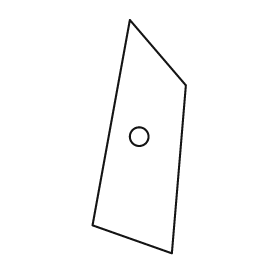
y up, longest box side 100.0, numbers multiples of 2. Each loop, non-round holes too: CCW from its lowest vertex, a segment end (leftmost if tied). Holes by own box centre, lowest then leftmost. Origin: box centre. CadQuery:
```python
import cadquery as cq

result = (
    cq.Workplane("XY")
    .moveTo(14.0, -50.0)
    .lineTo(20.0, 22.0)
    .lineTo(-4.0, 50.0)
    .lineTo(-20.0, -38.0)
    .close()
    .moveTo(0.0, 0.0)
    .circle(4.0)
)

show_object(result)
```